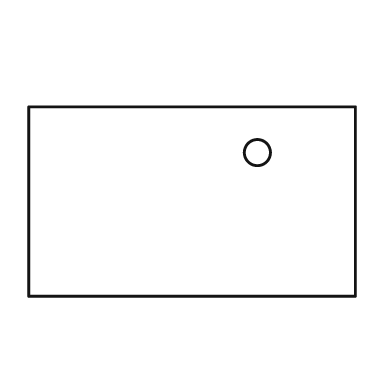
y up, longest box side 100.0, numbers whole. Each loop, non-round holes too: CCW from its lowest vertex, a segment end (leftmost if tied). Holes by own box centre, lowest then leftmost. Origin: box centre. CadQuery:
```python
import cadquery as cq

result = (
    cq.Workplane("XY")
    .moveTo(-50.0, -29.0)
    .lineTo(50.0, -29.0)
    .lineTo(50.0, 29.0)
    .lineTo(-50.0, 29.0)
    .close()
    .moveTo(20.0, 15.0)
    .circle(4.0)
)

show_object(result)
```